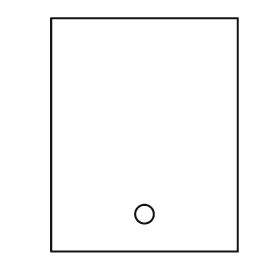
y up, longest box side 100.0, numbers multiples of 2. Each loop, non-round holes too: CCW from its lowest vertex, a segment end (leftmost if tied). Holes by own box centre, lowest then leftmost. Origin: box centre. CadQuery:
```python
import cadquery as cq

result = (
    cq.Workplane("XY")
    .moveTo(-40.0, -50.0)
    .lineTo(40.0, -50.0)
    .lineTo(40.0, 50.0)
    .lineTo(-40.0, 50.0)
    .close()
    .moveTo(0.0, -34.0)
    .circle(4.0)
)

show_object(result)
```